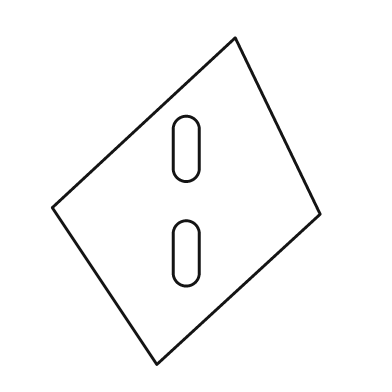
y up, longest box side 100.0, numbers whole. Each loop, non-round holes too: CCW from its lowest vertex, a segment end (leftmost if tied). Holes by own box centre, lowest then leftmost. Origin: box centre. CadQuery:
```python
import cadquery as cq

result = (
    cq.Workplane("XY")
    .moveTo(-9.0, -50.0)
    .lineTo(41.0, -4.0)
    .lineTo(15.0, 50.0)
    .lineTo(-41.0, -2.0)
    .close()
    .moveTo(-4.0, -22.0)
    .threePointArc((0.0, -26.0), (4.0, -22.0))
    .lineTo(4.0, -10.0)
    .threePointArc((0.0, -6.0), (-4.0, -10.0))
    .close()
    .moveTo(-4.0, 10.0)
    .threePointArc((0.0, 6.0), (4.0, 10.0))
    .lineTo(4.0, 22.0)
    .threePointArc((0.0, 26.0), (-4.0, 22.0))
    .close()
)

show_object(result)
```